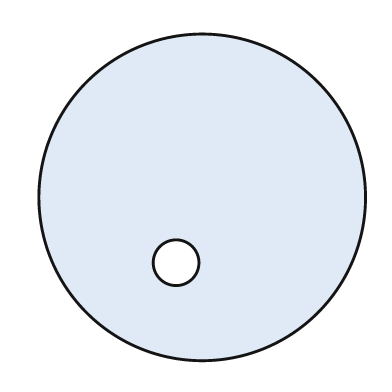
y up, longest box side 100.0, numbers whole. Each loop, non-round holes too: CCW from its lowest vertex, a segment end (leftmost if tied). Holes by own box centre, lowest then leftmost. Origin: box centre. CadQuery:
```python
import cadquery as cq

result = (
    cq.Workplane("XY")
    .moveTo(0.0, 0.0)
    .circle(50.0)
    .moveTo(-8.0, -20.0)
    .circle(7.0)
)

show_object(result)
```